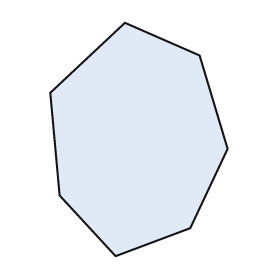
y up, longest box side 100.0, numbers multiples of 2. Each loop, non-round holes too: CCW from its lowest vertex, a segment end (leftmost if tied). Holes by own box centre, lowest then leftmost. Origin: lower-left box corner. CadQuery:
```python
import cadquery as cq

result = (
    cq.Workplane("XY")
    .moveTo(28.0, 0.0)
    .lineTo(60.0, 12.0)
    .lineTo(76.0, 46.0)
    .lineTo(64.0, 86.0)
    .lineTo(32.0, 100.0)
    .lineTo(0.0, 70.0)
    .lineTo(4.0, 26.0)
    .close()
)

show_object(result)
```